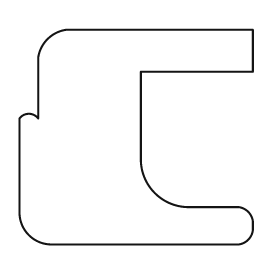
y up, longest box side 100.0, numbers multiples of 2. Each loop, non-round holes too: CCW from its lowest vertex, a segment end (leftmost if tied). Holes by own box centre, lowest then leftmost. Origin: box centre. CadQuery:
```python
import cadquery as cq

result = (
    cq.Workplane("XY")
    .moveTo(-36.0, -46.0)
    .lineTo(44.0, -46.0)
    .threePointArc((48.0, -44.0), (50.0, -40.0))
    .lineTo(50.0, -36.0)
    .threePointArc((48.0, -32.0), (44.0, -30.0))
    .lineTo(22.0, -30.0)
    .threePointArc((8.0, -24.0), (2.0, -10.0))
    .lineTo(2.0, 28.0)
    .lineTo(50.0, 28.0)
    .lineTo(50.0, 46.0)
    .lineTo(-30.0, 46.0)
    .threePointArc((-38.0, 42.0), (-42.0, 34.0))
    .lineTo(-42.0, 8.0)
    .threePointArc((-46.0, 10.0), (-50.0, 8.0))
    .lineTo(-50.0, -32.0)
    .threePointArc((-46.0, -42.0), (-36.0, -46.0))
    .close()
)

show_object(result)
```